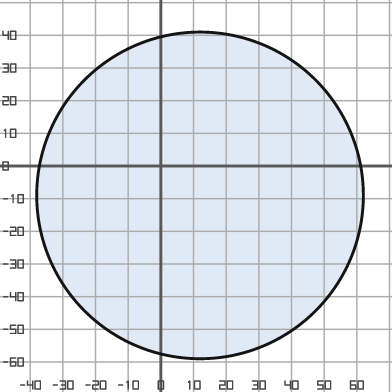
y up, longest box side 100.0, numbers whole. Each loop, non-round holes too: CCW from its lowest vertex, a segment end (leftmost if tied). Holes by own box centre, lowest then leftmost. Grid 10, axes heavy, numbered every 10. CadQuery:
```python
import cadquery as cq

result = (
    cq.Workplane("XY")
    .moveTo(12.0, -9.0)
    .circle(50.0)
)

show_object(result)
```